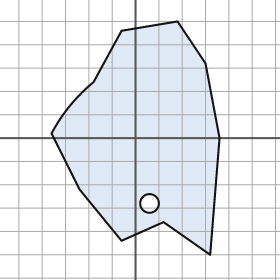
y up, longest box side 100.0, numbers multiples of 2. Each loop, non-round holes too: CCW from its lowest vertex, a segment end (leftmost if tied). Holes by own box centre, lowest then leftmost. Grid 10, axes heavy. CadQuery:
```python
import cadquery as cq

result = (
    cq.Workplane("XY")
    .moveTo(32.0, -50.0)
    .lineTo(36.0, 0.0)
    .lineTo(30.0, 32.0)
    .lineTo(18.0, 50.0)
    .lineTo(-6.0, 46.0)
    .lineTo(-18.0, 24.0)
    .threePointArc((-28.0, 14.0), (-36.0, 2.0))
    .lineTo(-24.0, -22.0)
    .lineTo(-6.0, -44.0)
    .lineTo(12.0, -36.0)
    .close()
    .moveTo(6.0, -28.0)
    .circle(4.0)
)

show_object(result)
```